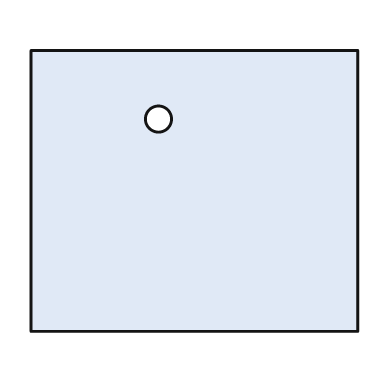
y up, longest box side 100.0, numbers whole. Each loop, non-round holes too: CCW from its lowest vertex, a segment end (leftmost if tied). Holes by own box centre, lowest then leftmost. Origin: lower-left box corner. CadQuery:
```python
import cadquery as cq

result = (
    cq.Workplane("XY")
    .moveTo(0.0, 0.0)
    .lineTo(100.0, 0.0)
    .lineTo(100.0, 86.0)
    .lineTo(0.0, 86.0)
    .close()
    .moveTo(39.0, 65.0)
    .circle(4.0)
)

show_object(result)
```